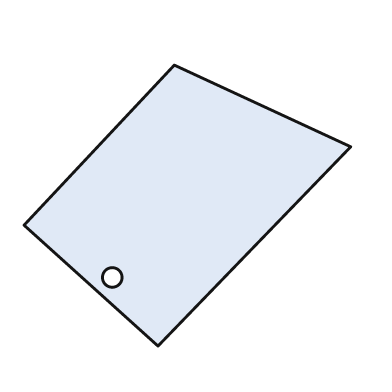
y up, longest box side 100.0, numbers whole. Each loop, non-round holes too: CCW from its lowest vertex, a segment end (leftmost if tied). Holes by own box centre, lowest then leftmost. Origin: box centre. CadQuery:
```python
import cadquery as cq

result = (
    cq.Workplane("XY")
    .moveTo(-9.0, -43.0)
    .lineTo(50.0, 18.0)
    .lineTo(-4.0, 43.0)
    .lineTo(-50.0, -6.0)
    .close()
    .moveTo(-23.0, -22.0)
    .circle(3.0)
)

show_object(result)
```